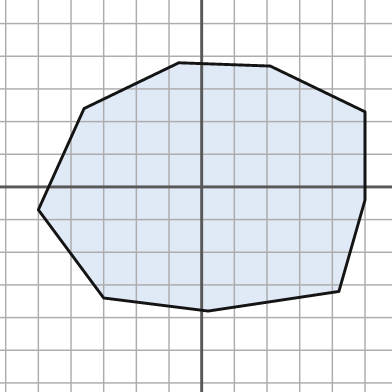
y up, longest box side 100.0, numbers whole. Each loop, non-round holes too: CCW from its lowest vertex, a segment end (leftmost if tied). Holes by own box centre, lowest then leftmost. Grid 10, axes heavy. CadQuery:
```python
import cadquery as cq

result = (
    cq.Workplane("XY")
    .moveTo(2.0, -38.0)
    .lineTo(42.0, -32.0)
    .lineTo(50.0, -4.0)
    .lineTo(50.0, 23.0)
    .lineTo(21.0, 37.0)
    .lineTo(-7.0, 38.0)
    .lineTo(-36.0, 24.0)
    .lineTo(-50.0, -7.0)
    .lineTo(-30.0, -34.0)
    .close()
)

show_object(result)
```